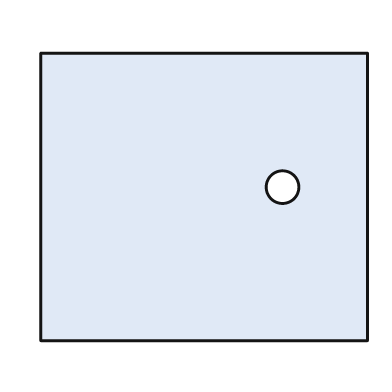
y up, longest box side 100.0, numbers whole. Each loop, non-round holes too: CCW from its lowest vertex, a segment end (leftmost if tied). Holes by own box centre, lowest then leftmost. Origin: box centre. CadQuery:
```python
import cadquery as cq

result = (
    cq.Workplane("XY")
    .moveTo(-50.0, -44.0)
    .lineTo(50.0, -44.0)
    .lineTo(50.0, 44.0)
    .lineTo(-50.0, 44.0)
    .close()
    .moveTo(24.0, 3.0)
    .circle(5.0)
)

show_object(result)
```